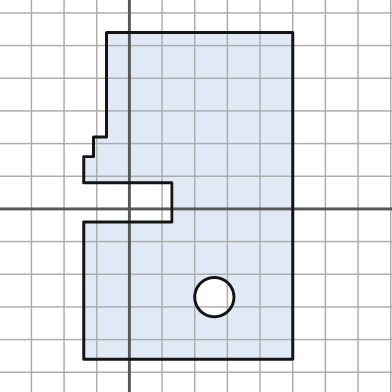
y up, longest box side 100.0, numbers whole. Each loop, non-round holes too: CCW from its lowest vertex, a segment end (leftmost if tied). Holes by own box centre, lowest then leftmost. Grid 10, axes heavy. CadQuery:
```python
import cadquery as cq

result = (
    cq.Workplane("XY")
    .moveTo(-14.0, -46.0)
    .lineTo(50.0, -46.0)
    .lineTo(50.0, 54.0)
    .lineTo(-7.0, 54.0)
    .lineTo(-7.0, 22.0)
    .lineTo(-11.0, 22.0)
    .lineTo(-11.0, 16.0)
    .lineTo(-14.0, 16.0)
    .lineTo(-14.0, 8.0)
    .lineTo(13.0, 8.0)
    .lineTo(13.0, -4.0)
    .lineTo(-14.0, -4.0)
    .close()
    .moveTo(26.0, -27.0)
    .circle(6.0)
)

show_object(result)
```